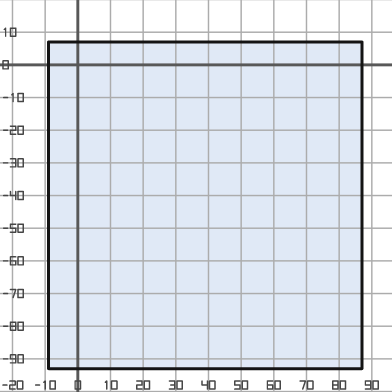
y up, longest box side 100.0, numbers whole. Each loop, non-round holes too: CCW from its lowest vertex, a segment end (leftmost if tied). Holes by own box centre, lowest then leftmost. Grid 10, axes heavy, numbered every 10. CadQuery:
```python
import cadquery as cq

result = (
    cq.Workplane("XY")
    .moveTo(-9.0, -93.0)
    .lineTo(87.0, -93.0)
    .lineTo(87.0, 7.0)
    .lineTo(-9.0, 7.0)
    .close()
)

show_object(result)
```